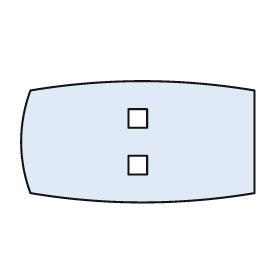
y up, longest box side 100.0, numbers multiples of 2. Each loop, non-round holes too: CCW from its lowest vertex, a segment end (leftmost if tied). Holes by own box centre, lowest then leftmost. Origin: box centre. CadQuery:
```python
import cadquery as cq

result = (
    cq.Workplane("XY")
    .moveTo(-46.0, -22.0)
    .threePointArc((2.0, -26.0), (50.0, -22.0))
    .lineTo(50.0, 22.0)
    .threePointArc((2.0, 26.0), (-46.0, 22.0))
    .threePointArc((-50.0, 0.0), (-46.0, -22.0))
    .close()
    .moveTo(-4.0, -14.0)
    .lineTo(4.0, -14.0)
    .lineTo(4.0, -6.0)
    .lineTo(-4.0, -6.0)
    .close()
    .moveTo(-4.0, 6.0)
    .lineTo(4.0, 6.0)
    .lineTo(4.0, 14.0)
    .lineTo(-4.0, 14.0)
    .close()
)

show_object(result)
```